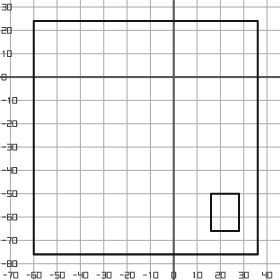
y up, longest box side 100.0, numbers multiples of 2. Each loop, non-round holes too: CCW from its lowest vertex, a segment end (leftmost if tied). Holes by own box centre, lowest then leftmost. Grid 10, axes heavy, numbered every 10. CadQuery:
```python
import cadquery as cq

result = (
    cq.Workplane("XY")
    .moveTo(-60.0, -76.0)
    .lineTo(36.0, -76.0)
    .lineTo(36.0, 24.0)
    .lineTo(-60.0, 24.0)
    .close()
    .moveTo(16.0, -66.0)
    .lineTo(28.0, -66.0)
    .lineTo(28.0, -50.0)
    .lineTo(16.0, -50.0)
    .close()
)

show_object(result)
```